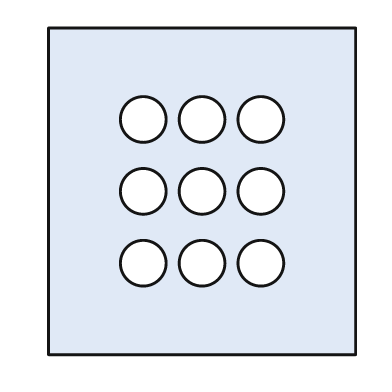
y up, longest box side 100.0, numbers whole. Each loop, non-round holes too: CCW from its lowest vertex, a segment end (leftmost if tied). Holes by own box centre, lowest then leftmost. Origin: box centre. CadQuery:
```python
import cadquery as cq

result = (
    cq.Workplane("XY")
    .moveTo(-47.0, -50.0)
    .lineTo(47.0, -50.0)
    .lineTo(47.0, 50.0)
    .lineTo(-47.0, 50.0)
    .close()
    .moveTo(-18.0, -22.0)
    .circle(7.0)
    .moveTo(0.0, -22.0)
    .circle(7.0)
    .moveTo(18.0, -22.0)
    .circle(7.0)
    .moveTo(-18.0, 0.0)
    .circle(7.0)
    .moveTo(0.0, 0.0)
    .circle(7.0)
    .moveTo(18.0, 0.0)
    .circle(7.0)
    .moveTo(-18.0, 22.0)
    .circle(7.0)
    .moveTo(0.0, 22.0)
    .circle(7.0)
    .moveTo(18.0, 22.0)
    .circle(7.0)
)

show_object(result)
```